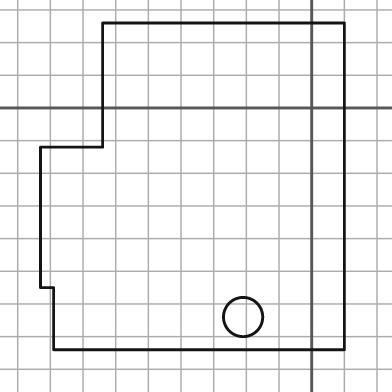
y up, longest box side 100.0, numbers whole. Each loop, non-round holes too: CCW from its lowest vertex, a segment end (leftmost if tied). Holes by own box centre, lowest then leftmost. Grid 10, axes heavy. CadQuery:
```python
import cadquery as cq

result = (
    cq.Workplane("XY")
    .moveTo(-79.0, -74.0)
    .lineTo(10.0, -74.0)
    .lineTo(10.0, 26.0)
    .lineTo(-64.0, 26.0)
    .lineTo(-64.0, -12.0)
    .lineTo(-83.0, -12.0)
    .lineTo(-83.0, -55.0)
    .lineTo(-79.0, -55.0)
    .close()
    .moveTo(-21.0, -64.0)
    .circle(6.0)
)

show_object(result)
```